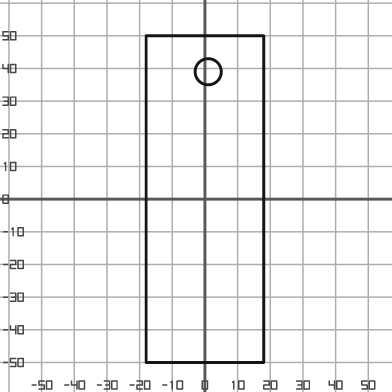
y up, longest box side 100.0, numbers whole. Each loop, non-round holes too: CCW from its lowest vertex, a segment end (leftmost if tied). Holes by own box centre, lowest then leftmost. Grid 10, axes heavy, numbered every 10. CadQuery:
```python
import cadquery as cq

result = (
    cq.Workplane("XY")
    .moveTo(-18.0, -50.0)
    .lineTo(18.0, -50.0)
    .lineTo(18.0, 50.0)
    .lineTo(-18.0, 50.0)
    .close()
    .moveTo(1.0, 39.0)
    .circle(4.0)
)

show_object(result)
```